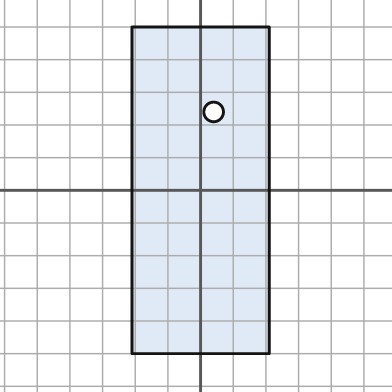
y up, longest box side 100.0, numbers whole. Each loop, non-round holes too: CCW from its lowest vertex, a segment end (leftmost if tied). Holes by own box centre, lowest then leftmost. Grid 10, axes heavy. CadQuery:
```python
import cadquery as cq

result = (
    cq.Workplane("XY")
    .moveTo(-21.0, -50.0)
    .lineTo(21.0, -50.0)
    .lineTo(21.0, 50.0)
    .lineTo(-21.0, 50.0)
    .close()
    .moveTo(4.0, 24.0)
    .circle(3.0)
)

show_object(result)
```